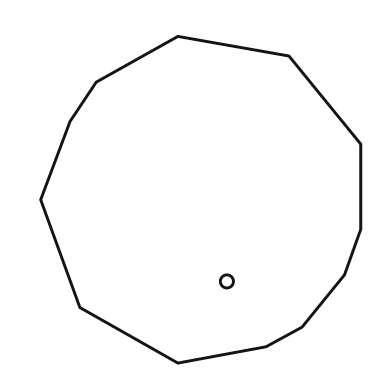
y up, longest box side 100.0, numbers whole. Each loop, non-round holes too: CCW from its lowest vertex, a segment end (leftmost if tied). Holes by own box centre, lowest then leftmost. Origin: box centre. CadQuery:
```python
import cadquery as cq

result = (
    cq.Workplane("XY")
    .moveTo(-7.0, -50.0)
    .lineTo(20.0, -45.0)
    .lineTo(31.0, -39.0)
    .lineTo(44.0, -23.0)
    .lineTo(49.0, -9.0)
    .lineTo(49.0, 17.0)
    .lineTo(27.0, 44.0)
    .lineTo(-7.0, 50.0)
    .lineTo(-32.0, 36.0)
    .lineTo(-40.0, 24.0)
    .lineTo(-49.0, 0.0)
    .lineTo(-37.0, -33.0)
    .close()
    .moveTo(8.0, -25.0)
    .circle(2.0)
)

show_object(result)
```